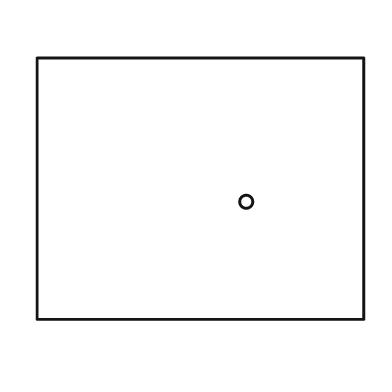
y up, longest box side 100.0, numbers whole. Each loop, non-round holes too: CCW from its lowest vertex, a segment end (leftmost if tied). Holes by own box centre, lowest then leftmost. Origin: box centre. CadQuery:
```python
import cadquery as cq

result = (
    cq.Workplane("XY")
    .moveTo(-50.0, -40.0)
    .lineTo(50.0, -40.0)
    .lineTo(50.0, 40.0)
    .lineTo(-50.0, 40.0)
    .close()
    .moveTo(14.0, -4.0)
    .circle(2.0)
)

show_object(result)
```